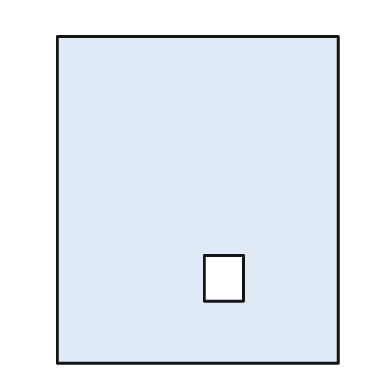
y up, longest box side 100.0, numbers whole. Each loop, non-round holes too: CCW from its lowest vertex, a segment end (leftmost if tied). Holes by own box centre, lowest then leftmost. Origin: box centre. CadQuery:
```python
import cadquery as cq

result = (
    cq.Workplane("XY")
    .moveTo(-43.0, -50.0)
    .lineTo(43.0, -50.0)
    .lineTo(43.0, 50.0)
    .lineTo(-43.0, 50.0)
    .close()
    .moveTo(2.0, -31.0)
    .lineTo(14.0, -31.0)
    .lineTo(14.0, -17.0)
    .lineTo(2.0, -17.0)
    .close()
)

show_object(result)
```